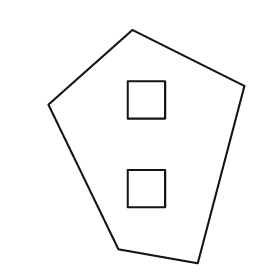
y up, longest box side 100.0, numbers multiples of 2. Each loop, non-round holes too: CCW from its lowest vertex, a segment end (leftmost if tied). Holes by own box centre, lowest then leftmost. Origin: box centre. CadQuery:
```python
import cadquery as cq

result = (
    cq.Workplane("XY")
    .moveTo(22.0, -50.0)
    .lineTo(42.0, 26.0)
    .lineTo(-6.0, 50.0)
    .lineTo(-42.0, 18.0)
    .lineTo(-12.0, -44.0)
    .close()
    .moveTo(-8.0, -26.0)
    .lineTo(8.0, -26.0)
    .lineTo(8.0, -10.0)
    .lineTo(-8.0, -10.0)
    .close()
    .moveTo(-8.0, 12.0)
    .lineTo(8.0, 12.0)
    .lineTo(8.0, 28.0)
    .lineTo(-8.0, 28.0)
    .close()
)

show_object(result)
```